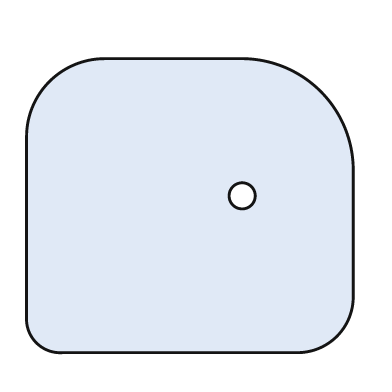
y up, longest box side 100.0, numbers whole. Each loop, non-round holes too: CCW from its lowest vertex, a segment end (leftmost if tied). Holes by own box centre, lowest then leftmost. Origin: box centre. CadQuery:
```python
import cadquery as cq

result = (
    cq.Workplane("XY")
    .moveTo(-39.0, -45.0)
    .lineTo(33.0, -45.0)
    .threePointArc((45.0, -40.0), (50.0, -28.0))
    .lineTo(50.0, 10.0)
    .threePointArc((40.0, 35.0), (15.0, 45.0))
    .lineTo(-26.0, 45.0)
    .threePointArc((-43.0, 38.0), (-50.0, 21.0))
    .lineTo(-50.0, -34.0)
    .threePointArc((-47.0, -42.0), (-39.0, -45.0))
    .close()
    .moveTo(16.0, 3.0)
    .circle(4.0)
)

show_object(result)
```